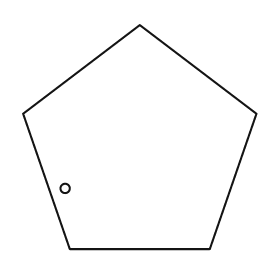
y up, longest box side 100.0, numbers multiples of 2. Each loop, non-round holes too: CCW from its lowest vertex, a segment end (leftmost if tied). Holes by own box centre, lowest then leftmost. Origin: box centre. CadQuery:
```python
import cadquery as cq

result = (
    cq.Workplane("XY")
    .moveTo(-30.0, -48.0)
    .lineTo(30.0, -48.0)
    .lineTo(50.0, 10.0)
    .lineTo(0.0, 48.0)
    .lineTo(-50.0, 10.0)
    .close()
    .moveTo(-32.0, -22.0)
    .circle(2.0)
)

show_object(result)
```